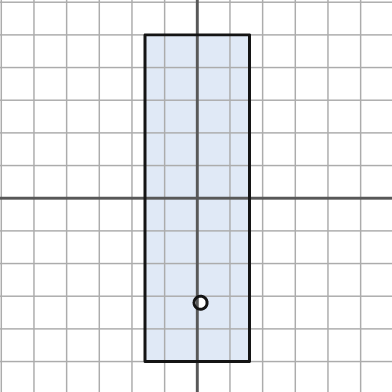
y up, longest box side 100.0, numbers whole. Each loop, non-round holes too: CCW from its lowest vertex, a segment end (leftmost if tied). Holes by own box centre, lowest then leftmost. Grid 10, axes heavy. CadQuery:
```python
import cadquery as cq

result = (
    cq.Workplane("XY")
    .moveTo(-16.0, -50.0)
    .lineTo(16.0, -50.0)
    .lineTo(16.0, 50.0)
    .lineTo(-16.0, 50.0)
    .close()
    .moveTo(1.0, -32.0)
    .circle(2.0)
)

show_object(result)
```